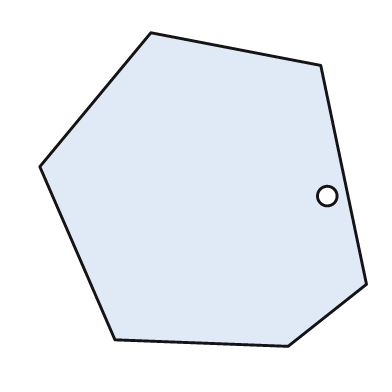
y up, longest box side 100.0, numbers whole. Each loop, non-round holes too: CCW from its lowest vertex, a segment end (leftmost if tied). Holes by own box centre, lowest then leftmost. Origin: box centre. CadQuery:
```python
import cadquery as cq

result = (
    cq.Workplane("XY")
    .moveTo(26.0, -48.0)
    .lineTo(50.0, -29.0)
    .lineTo(36.0, 38.0)
    .lineTo(-16.0, 48.0)
    .lineTo(-50.0, 7.0)
    .lineTo(-27.0, -46.0)
    .close()
    .moveTo(38.0, -2.0)
    .circle(3.0)
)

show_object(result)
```